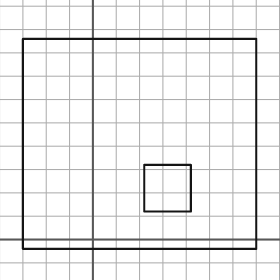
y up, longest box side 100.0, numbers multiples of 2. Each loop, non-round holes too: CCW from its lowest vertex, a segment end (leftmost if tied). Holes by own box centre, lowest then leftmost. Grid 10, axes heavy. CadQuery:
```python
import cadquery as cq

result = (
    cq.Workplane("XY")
    .moveTo(-30.0, -4.0)
    .lineTo(70.0, -4.0)
    .lineTo(70.0, 86.0)
    .lineTo(-30.0, 86.0)
    .close()
    .moveTo(22.0, 12.0)
    .lineTo(42.0, 12.0)
    .lineTo(42.0, 32.0)
    .lineTo(22.0, 32.0)
    .close()
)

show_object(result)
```